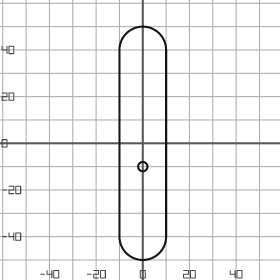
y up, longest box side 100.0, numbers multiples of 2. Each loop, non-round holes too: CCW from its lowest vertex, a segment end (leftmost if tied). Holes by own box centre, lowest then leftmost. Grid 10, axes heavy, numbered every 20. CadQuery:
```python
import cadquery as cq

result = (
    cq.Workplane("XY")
    .moveTo(-10.0, -40.0)
    .threePointArc((0.0, -50.0), (10.0, -40.0))
    .lineTo(10.0, 40.0)
    .threePointArc((0.0, 50.0), (-10.0, 40.0))
    .close()
    .moveTo(0.0, -10.0)
    .circle(2.0)
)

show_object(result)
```